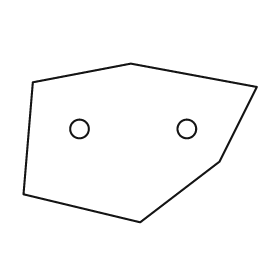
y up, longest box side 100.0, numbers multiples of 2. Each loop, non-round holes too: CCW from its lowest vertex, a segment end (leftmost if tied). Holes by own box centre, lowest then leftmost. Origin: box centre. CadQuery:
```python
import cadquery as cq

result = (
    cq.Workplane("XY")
    .moveTo(0.0, -34.0)
    .lineTo(34.0, -8.0)
    .lineTo(50.0, 24.0)
    .lineTo(-4.0, 34.0)
    .lineTo(-46.0, 26.0)
    .lineTo(-50.0, -22.0)
    .close()
    .moveTo(-26.0, 6.0)
    .circle(4.0)
    .moveTo(20.0, 6.0)
    .circle(4.0)
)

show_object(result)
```